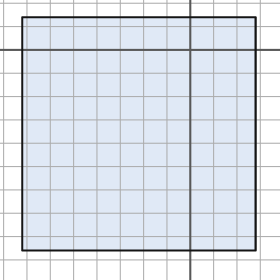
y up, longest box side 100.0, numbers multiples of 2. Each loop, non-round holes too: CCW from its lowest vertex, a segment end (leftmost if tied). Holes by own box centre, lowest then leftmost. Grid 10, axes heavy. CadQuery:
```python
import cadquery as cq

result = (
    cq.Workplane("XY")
    .moveTo(-72.0, -86.0)
    .lineTo(28.0, -86.0)
    .lineTo(28.0, 14.0)
    .lineTo(-72.0, 14.0)
    .close()
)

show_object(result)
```